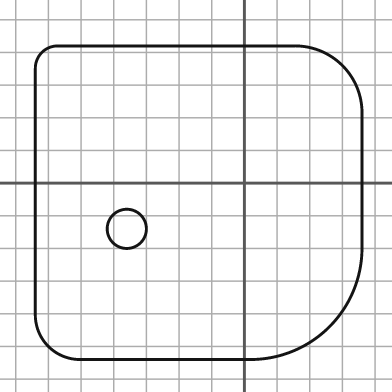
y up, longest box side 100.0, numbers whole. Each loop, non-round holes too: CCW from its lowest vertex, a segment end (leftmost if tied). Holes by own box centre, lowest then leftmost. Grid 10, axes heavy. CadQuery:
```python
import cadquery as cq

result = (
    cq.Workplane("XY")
    .moveTo(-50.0, -54.0)
    .lineTo(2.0, -54.0)
    .threePointArc((26.0, -44.0), (36.0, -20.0))
    .lineTo(36.0, 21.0)
    .threePointArc((30.0, 36.0), (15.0, 42.0))
    .lineTo(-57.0, 42.0)
    .threePointArc((-62.0, 40.0), (-64.0, 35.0))
    .lineTo(-64.0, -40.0)
    .threePointArc((-60.0, -50.0), (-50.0, -54.0))
    .close()
    .moveTo(-36.0, -14.0)
    .circle(6.0)
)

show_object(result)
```